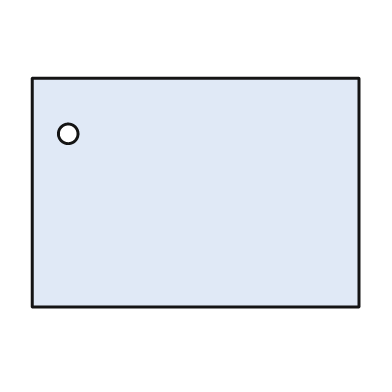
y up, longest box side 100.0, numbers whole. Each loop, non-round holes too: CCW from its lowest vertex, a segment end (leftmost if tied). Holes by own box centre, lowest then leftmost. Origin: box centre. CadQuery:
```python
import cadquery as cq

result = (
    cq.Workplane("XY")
    .moveTo(-50.0, -35.0)
    .lineTo(50.0, -35.0)
    .lineTo(50.0, 35.0)
    .lineTo(-50.0, 35.0)
    .close()
    .moveTo(-39.0, 18.0)
    .circle(3.0)
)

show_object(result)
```